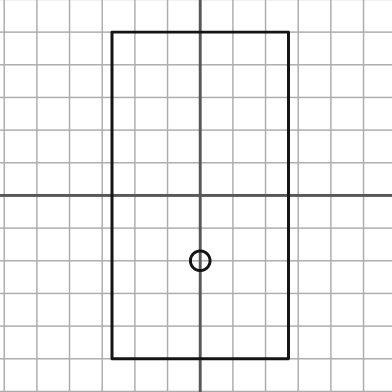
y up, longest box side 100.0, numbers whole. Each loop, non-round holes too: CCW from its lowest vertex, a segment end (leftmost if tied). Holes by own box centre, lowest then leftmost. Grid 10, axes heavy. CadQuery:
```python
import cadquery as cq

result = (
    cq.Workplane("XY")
    .moveTo(-27.0, -50.0)
    .lineTo(27.0, -50.0)
    .lineTo(27.0, 50.0)
    .lineTo(-27.0, 50.0)
    .close()
    .moveTo(0.0, -20.0)
    .circle(3.0)
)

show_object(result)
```